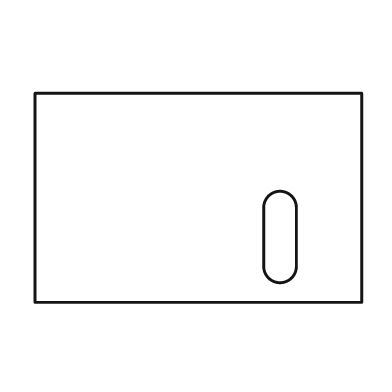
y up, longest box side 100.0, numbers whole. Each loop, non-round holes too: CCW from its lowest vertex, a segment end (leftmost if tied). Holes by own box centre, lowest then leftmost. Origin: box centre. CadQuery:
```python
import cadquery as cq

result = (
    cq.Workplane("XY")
    .moveTo(-50.0, -32.0)
    .lineTo(50.0, -32.0)
    .lineTo(50.0, 32.0)
    .lineTo(-50.0, 32.0)
    .close()
    .moveTo(20.0, -21.0)
    .threePointArc((25.0, -26.0), (30.0, -21.0))
    .lineTo(30.0, -3.0)
    .threePointArc((25.0, 2.0), (20.0, -3.0))
    .close()
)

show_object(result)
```